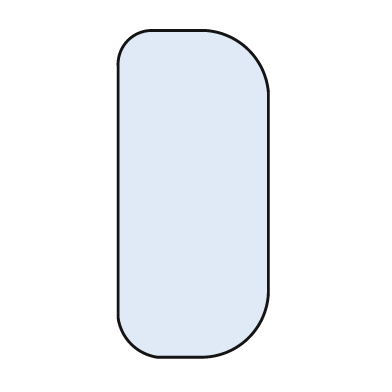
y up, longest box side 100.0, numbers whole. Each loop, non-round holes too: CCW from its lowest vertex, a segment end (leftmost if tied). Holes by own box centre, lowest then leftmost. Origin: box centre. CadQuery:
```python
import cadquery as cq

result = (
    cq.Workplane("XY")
    .moveTo(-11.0, -50.0)
    .lineTo(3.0, -50.0)
    .threePointArc((17.0, -44.0), (23.0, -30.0))
    .lineTo(23.0, 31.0)
    .threePointArc((17.0, 44.0), (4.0, 50.0))
    .lineTo(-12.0, 50.0)
    .threePointArc((-20.0, 47.0), (-23.0, 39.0))
    .lineTo(-23.0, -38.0)
    .threePointArc((-19.0, -46.0), (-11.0, -50.0))
    .close()
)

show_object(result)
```